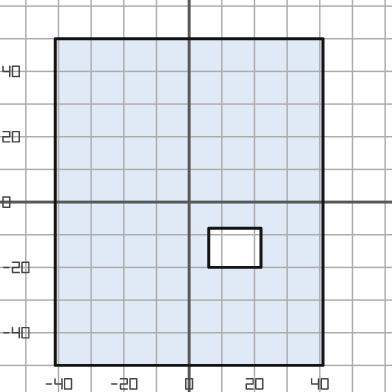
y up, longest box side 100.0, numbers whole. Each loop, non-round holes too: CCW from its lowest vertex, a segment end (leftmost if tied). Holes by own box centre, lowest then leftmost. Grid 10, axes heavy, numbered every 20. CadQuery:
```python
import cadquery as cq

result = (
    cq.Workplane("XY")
    .moveTo(-41.0, -50.0)
    .lineTo(41.0, -50.0)
    .lineTo(41.0, 50.0)
    .lineTo(-41.0, 50.0)
    .close()
    .moveTo(6.0, -20.0)
    .lineTo(22.0, -20.0)
    .lineTo(22.0, -8.0)
    .lineTo(6.0, -8.0)
    .close()
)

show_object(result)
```